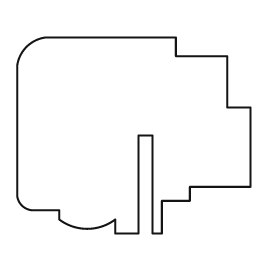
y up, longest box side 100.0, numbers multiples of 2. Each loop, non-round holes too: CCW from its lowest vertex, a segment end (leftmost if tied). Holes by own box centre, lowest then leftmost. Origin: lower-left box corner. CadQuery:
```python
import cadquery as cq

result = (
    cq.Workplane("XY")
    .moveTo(42.0, 0.0)
    .lineTo(52.0, 0.0)
    .lineTo(52.0, 42.0)
    .lineTo(58.0, 42.0)
    .lineTo(58.0, 0.0)
    .lineTo(62.0, 0.0)
    .lineTo(62.0, 14.0)
    .lineTo(74.0, 14.0)
    .lineTo(74.0, 20.0)
    .lineTo(100.0, 20.0)
    .lineTo(100.0, 54.0)
    .lineTo(90.0, 54.0)
    .lineTo(90.0, 76.0)
    .lineTo(68.0, 76.0)
    .lineTo(68.0, 84.0)
    .lineTo(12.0, 84.0)
    .threePointArc((4.0, 80.0), (0.0, 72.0))
    .lineTo(0.0, 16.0)
    .threePointArc((2.0, 12.0), (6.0, 10.0))
    .lineTo(18.0, 10.0)
    .lineTo(18.0, 6.0)
    .threePointArc((30.0, 2.0), (42.0, 6.0))
    .close()
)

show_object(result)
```